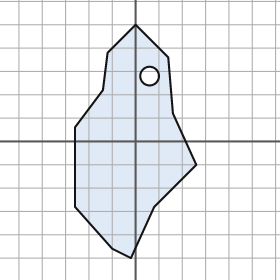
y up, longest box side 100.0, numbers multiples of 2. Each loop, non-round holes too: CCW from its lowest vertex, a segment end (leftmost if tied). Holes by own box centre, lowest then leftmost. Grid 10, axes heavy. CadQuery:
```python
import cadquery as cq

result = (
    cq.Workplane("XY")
    .moveTo(-2.0, -50.0)
    .lineTo(8.0, -28.0)
    .lineTo(26.0, -10.0)
    .lineTo(16.0, 12.0)
    .lineTo(14.0, 36.0)
    .lineTo(0.0, 50.0)
    .lineTo(-12.0, 38.0)
    .lineTo(-14.0, 22.0)
    .lineTo(-26.0, 6.0)
    .lineTo(-26.0, -28.0)
    .lineTo(-10.0, -46.0)
    .close()
    .moveTo(6.0, 28.0)
    .circle(4.0)
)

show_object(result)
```